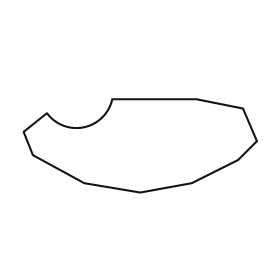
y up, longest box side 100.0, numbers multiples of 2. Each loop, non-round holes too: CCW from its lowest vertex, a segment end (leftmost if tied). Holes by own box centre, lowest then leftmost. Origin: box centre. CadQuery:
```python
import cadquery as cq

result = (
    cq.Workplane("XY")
    .moveTo(0.0, -20.0)
    .lineTo(22.0, -16.0)
    .lineTo(42.0, -6.0)
    .lineTo(50.0, 2.0)
    .lineTo(44.0, 16.0)
    .lineTo(24.0, 20.0)
    .lineTo(-12.0, 20.0)
    .threePointArc((-24.0, 8.0), (-40.0, 14.0))
    .lineTo(-50.0, 6.0)
    .lineTo(-46.0, -4.0)
    .lineTo(-24.0, -16.0)
    .close()
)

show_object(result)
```